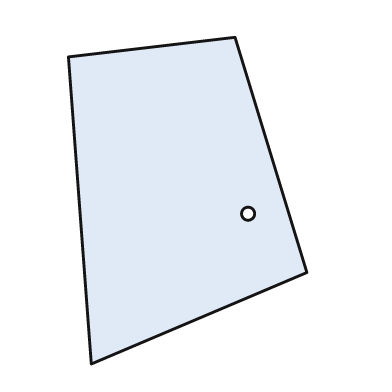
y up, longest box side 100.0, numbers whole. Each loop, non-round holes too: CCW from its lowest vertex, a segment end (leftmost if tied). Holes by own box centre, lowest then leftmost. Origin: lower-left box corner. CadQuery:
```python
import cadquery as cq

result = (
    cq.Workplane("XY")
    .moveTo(7.0, 0.0)
    .lineTo(73.0, 28.0)
    .lineTo(51.0, 100.0)
    .lineTo(0.0, 94.0)
    .close()
    .moveTo(55.0, 46.0)
    .circle(2.0)
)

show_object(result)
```